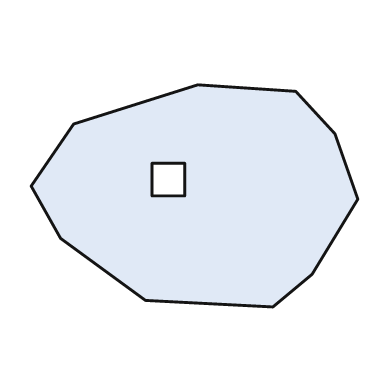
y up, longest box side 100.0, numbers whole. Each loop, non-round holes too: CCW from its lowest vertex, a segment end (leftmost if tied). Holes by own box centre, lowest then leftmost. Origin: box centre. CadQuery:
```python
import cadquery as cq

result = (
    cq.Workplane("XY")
    .moveTo(24.0, -34.0)
    .lineTo(36.0, -24.0)
    .lineTo(50.0, -1.0)
    .lineTo(43.0, 19.0)
    .lineTo(31.0, 32.0)
    .lineTo(1.0, 34.0)
    .lineTo(-37.0, 22.0)
    .lineTo(-50.0, 3.0)
    .lineTo(-41.0, -13.0)
    .lineTo(-15.0, -32.0)
    .close()
    .moveTo(-13.0, 0.0)
    .lineTo(-3.0, 0.0)
    .lineTo(-3.0, 10.0)
    .lineTo(-13.0, 10.0)
    .close()
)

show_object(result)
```